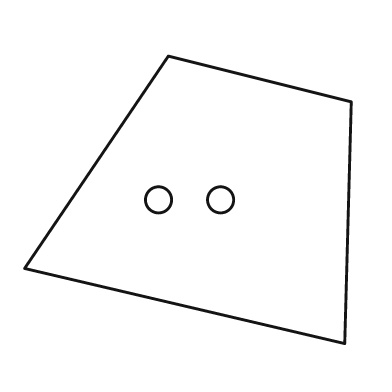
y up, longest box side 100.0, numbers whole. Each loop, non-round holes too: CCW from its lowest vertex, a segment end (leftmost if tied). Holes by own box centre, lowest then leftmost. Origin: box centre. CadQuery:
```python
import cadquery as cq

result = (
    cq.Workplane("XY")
    .moveTo(48.0, -44.0)
    .lineTo(50.0, 30.0)
    .lineTo(-6.0, 44.0)
    .lineTo(-50.0, -21.0)
    .close()
    .moveTo(-9.0, 0.0)
    .circle(4.0)
    .moveTo(10.0, 0.0)
    .circle(4.0)
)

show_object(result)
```